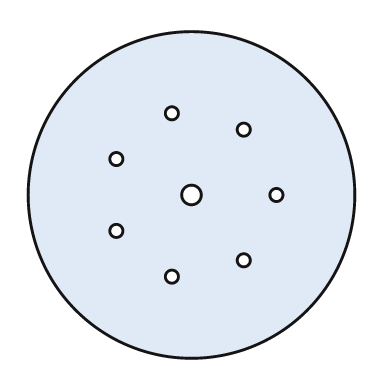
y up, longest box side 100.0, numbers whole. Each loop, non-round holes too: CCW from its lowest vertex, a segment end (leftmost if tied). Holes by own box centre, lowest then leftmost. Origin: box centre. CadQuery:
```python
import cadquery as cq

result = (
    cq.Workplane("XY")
    .moveTo(0.0, 0.0)
    .circle(50.0)
    .moveTo(-6.0, -25.0)
    .circle(2.0)
    .moveTo(16.0, -20.0)
    .circle(2.0)
    .moveTo(-23.0, -11.0)
    .circle(2.0)
    .moveTo(0.0, 0.0)
    .circle(3.0)
    .moveTo(26.0, 0.0)
    .circle(2.0)
    .moveTo(-23.0, 11.0)
    .circle(2.0)
    .moveTo(16.0, 20.0)
    .circle(2.0)
    .moveTo(-6.0, 25.0)
    .circle(2.0)
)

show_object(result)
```